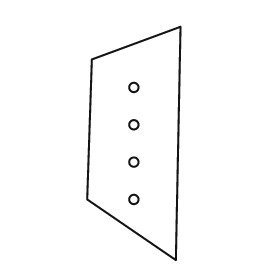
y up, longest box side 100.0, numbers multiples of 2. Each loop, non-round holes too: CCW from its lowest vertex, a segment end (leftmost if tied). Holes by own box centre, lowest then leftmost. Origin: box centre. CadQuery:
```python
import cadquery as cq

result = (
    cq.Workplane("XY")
    .moveTo(18.0, -50.0)
    .lineTo(20.0, 50.0)
    .lineTo(-18.0, 36.0)
    .lineTo(-20.0, -24.0)
    .close()
    .moveTo(0.0, -24.0)
    .circle(2.0)
    .moveTo(0.0, -8.0)
    .circle(2.0)
    .moveTo(0.0, 8.0)
    .circle(2.0)
    .moveTo(0.0, 24.0)
    .circle(2.0)
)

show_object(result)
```